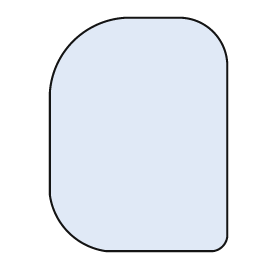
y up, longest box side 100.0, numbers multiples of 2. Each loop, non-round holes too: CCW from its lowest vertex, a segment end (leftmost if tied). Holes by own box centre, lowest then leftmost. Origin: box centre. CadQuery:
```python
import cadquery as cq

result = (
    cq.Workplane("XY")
    .moveTo(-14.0, -50.0)
    .lineTo(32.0, -50.0)
    .threePointArc((36.0, -48.0), (38.0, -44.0))
    .lineTo(38.0, 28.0)
    .threePointArc((32.0, 44.0), (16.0, 50.0))
    .lineTo(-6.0, 50.0)
    .threePointArc((-28.0, 40.0), (-38.0, 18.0))
    .lineTo(-38.0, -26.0)
    .threePointArc((-30.0, -42.0), (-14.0, -50.0))
    .close()
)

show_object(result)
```